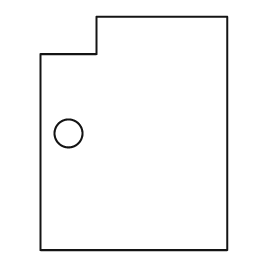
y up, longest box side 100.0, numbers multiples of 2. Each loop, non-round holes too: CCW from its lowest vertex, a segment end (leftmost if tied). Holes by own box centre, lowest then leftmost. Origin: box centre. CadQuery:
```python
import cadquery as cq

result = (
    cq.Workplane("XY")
    .moveTo(-40.0, -50.0)
    .lineTo(40.0, -50.0)
    .lineTo(40.0, 50.0)
    .lineTo(-16.0, 50.0)
    .lineTo(-16.0, 34.0)
    .lineTo(-40.0, 34.0)
    .close()
    .moveTo(-28.0, 0.0)
    .circle(6.0)
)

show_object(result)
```